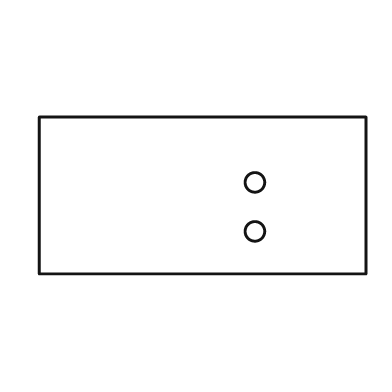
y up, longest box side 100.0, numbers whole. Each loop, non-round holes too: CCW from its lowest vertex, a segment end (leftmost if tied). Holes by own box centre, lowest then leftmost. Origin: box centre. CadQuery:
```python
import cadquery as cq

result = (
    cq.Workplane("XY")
    .moveTo(-50.0, -24.0)
    .lineTo(50.0, -24.0)
    .lineTo(50.0, 24.0)
    .lineTo(-50.0, 24.0)
    .close()
    .moveTo(16.0, -11.0)
    .circle(3.0)
    .moveTo(16.0, 4.0)
    .circle(3.0)
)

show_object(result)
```